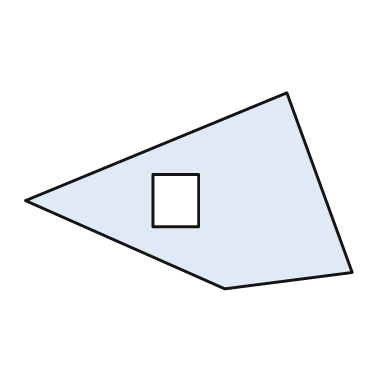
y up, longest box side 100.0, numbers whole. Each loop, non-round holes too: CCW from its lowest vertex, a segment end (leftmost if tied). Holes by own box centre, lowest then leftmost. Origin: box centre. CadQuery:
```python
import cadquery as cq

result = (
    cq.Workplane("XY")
    .moveTo(11.0, -30.0)
    .lineTo(50.0, -25.0)
    .lineTo(30.0, 30.0)
    .lineTo(-50.0, -3.0)
    .close()
    .moveTo(-11.0, -11.0)
    .lineTo(3.0, -11.0)
    .lineTo(3.0, 5.0)
    .lineTo(-11.0, 5.0)
    .close()
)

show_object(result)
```